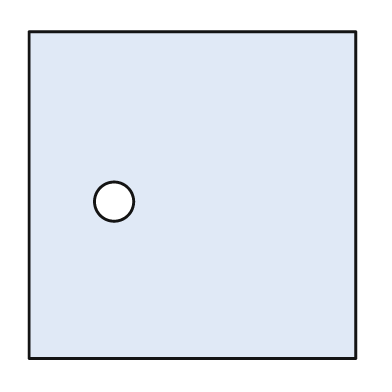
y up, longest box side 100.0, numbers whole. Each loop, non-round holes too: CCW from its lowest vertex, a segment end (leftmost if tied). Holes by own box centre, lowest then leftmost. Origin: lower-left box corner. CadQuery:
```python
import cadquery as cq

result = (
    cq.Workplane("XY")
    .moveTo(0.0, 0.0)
    .lineTo(100.0, 0.0)
    .lineTo(100.0, 100.0)
    .lineTo(0.0, 100.0)
    .close()
    .moveTo(26.0, 48.0)
    .circle(6.0)
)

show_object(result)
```